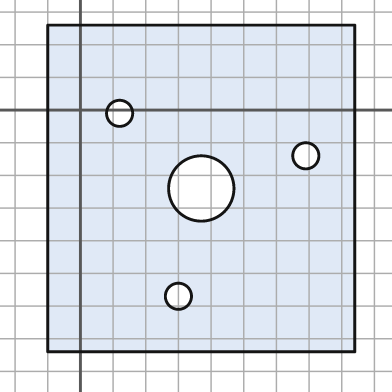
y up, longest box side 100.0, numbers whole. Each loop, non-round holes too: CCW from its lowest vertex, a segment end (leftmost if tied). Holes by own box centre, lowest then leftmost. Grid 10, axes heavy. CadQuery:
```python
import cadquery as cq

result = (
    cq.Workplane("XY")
    .moveTo(-10.0, -74.0)
    .lineTo(84.0, -74.0)
    .lineTo(84.0, 26.0)
    .lineTo(-10.0, 26.0)
    .close()
    .moveTo(30.0, -57.0)
    .circle(4.0)
    .moveTo(37.0, -24.0)
    .circle(10.0)
    .moveTo(69.0, -14.0)
    .circle(4.0)
    .moveTo(12.0, -1.0)
    .circle(4.0)
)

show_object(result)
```